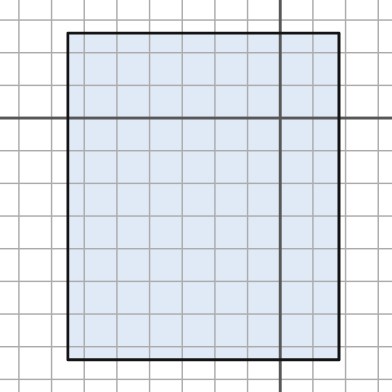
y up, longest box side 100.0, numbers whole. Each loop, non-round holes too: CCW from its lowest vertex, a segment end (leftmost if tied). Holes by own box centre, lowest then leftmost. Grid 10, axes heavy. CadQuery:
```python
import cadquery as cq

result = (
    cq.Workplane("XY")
    .moveTo(-65.0, -74.0)
    .lineTo(18.0, -74.0)
    .lineTo(18.0, 26.0)
    .lineTo(-65.0, 26.0)
    .close()
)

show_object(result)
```